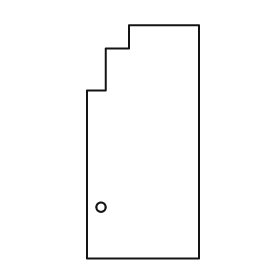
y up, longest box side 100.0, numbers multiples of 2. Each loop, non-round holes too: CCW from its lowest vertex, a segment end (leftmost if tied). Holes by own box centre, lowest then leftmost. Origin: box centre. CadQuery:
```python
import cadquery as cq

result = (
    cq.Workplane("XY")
    .moveTo(-24.0, -50.0)
    .lineTo(24.0, -50.0)
    .lineTo(24.0, 50.0)
    .lineTo(-6.0, 50.0)
    .lineTo(-6.0, 40.0)
    .lineTo(-16.0, 40.0)
    .lineTo(-16.0, 22.0)
    .lineTo(-24.0, 22.0)
    .close()
    .moveTo(-18.0, -28.0)
    .circle(2.0)
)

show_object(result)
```